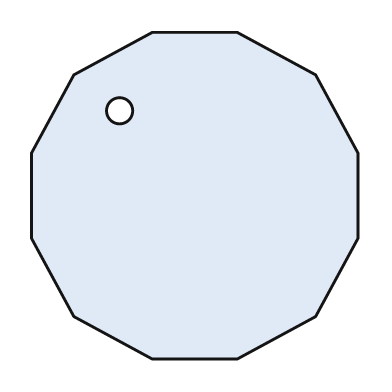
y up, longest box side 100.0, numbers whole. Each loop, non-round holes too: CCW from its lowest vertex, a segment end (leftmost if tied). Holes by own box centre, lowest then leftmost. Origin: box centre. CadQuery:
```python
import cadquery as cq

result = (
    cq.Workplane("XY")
    .moveTo(-13.0, -50.0)
    .lineTo(13.0, -50.0)
    .lineTo(37.0, -37.0)
    .lineTo(50.0, -13.0)
    .lineTo(50.0, 13.0)
    .lineTo(37.0, 37.0)
    .lineTo(13.0, 50.0)
    .lineTo(-13.0, 50.0)
    .lineTo(-37.0, 37.0)
    .lineTo(-50.0, 13.0)
    .lineTo(-50.0, -13.0)
    .lineTo(-37.0, -37.0)
    .close()
    .moveTo(-23.0, 26.0)
    .circle(4.0)
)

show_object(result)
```